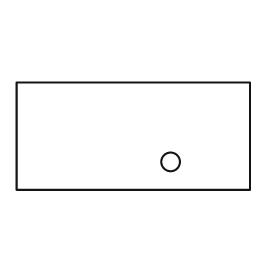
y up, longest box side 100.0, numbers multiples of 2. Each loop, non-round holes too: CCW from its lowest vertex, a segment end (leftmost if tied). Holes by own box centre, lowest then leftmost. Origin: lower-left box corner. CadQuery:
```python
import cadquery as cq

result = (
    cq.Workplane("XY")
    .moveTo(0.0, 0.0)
    .lineTo(100.0, 0.0)
    .lineTo(100.0, 46.0)
    .lineTo(0.0, 46.0)
    .close()
    .moveTo(66.0, 12.0)
    .circle(4.0)
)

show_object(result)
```